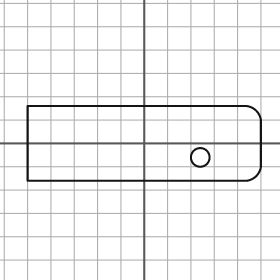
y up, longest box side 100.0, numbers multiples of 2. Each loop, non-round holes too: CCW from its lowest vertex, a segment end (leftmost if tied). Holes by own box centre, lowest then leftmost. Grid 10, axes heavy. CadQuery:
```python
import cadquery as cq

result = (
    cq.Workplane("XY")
    .moveTo(-50.0, -16.0)
    .lineTo(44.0, -16.0)
    .threePointArc((48.0, -14.0), (50.0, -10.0))
    .lineTo(50.0, 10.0)
    .threePointArc((48.0, 14.0), (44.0, 16.0))
    .lineTo(-50.0, 16.0)
    .close()
    .moveTo(24.0, -6.0)
    .circle(4.0)
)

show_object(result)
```